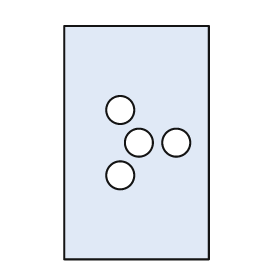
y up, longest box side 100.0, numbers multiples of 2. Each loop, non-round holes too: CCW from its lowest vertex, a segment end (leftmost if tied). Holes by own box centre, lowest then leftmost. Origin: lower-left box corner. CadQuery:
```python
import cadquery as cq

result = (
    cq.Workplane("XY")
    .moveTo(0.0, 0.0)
    .lineTo(62.0, 0.0)
    .lineTo(62.0, 100.0)
    .lineTo(0.0, 100.0)
    .close()
    .moveTo(24.0, 36.0)
    .circle(6.0)
    .moveTo(32.0, 50.0)
    .circle(6.0)
    .moveTo(48.0, 50.0)
    .circle(6.0)
    .moveTo(24.0, 64.0)
    .circle(6.0)
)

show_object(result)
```